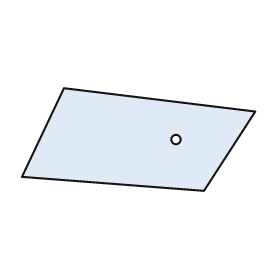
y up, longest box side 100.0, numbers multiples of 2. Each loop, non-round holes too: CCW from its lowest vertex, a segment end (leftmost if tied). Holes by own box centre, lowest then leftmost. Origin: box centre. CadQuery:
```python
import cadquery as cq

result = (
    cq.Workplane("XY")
    .moveTo(28.0, -22.0)
    .lineTo(50.0, 12.0)
    .lineTo(-32.0, 22.0)
    .lineTo(-50.0, -16.0)
    .close()
    .moveTo(16.0, 0.0)
    .circle(2.0)
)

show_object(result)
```